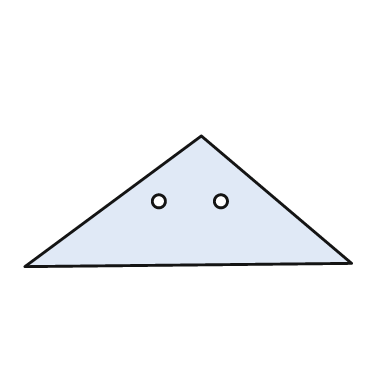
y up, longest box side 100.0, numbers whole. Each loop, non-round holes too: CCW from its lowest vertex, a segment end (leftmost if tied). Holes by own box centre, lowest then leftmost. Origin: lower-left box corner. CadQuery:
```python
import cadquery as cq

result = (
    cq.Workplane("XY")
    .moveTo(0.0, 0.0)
    .lineTo(100.0, 1.0)
    .lineTo(54.0, 40.0)
    .close()
    .moveTo(41.0, 20.0)
    .circle(2.0)
    .moveTo(60.0, 20.0)
    .circle(2.0)
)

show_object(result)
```